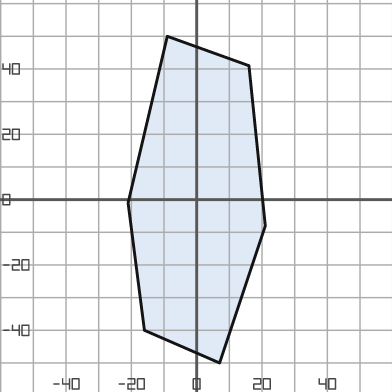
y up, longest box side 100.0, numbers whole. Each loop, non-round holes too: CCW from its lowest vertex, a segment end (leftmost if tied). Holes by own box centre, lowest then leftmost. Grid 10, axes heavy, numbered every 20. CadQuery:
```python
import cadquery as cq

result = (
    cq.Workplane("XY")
    .moveTo(7.0, -50.0)
    .lineTo(21.0, -8.0)
    .lineTo(16.0, 41.0)
    .lineTo(-9.0, 50.0)
    .lineTo(-21.0, -1.0)
    .lineTo(-16.0, -40.0)
    .close()
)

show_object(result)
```